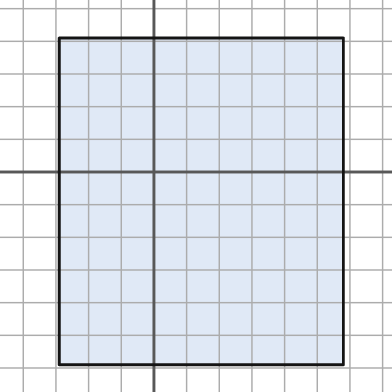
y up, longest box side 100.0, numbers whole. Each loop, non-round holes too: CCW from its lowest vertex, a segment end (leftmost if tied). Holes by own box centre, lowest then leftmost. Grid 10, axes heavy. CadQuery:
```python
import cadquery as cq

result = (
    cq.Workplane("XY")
    .moveTo(-29.0, -59.0)
    .lineTo(58.0, -59.0)
    .lineTo(58.0, 41.0)
    .lineTo(-29.0, 41.0)
    .close()
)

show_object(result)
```